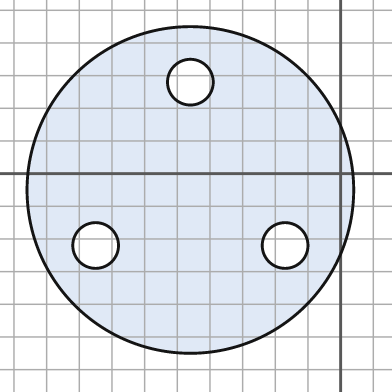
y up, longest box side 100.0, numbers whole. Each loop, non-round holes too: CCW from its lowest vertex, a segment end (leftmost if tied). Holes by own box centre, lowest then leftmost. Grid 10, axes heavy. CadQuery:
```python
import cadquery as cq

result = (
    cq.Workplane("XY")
    .moveTo(-46.0, -5.0)
    .circle(50.0)
    .moveTo(-75.0, -22.0)
    .circle(7.0)
    .moveTo(-17.0, -22.0)
    .circle(7.0)
    .moveTo(-46.0, 28.0)
    .circle(7.0)
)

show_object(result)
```